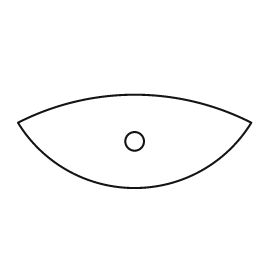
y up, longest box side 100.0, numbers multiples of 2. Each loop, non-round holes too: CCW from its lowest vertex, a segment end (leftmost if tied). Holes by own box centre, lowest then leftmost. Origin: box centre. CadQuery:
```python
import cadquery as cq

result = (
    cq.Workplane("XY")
    .moveTo(-50.0, 8.0)
    .threePointArc((0.0, -20.0), (50.0, 8.0))
    .threePointArc((0.0, 20.0), (-50.0, 8.0))
    .close()
    .moveTo(0.0, 0.0)
    .circle(4.0)
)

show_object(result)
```